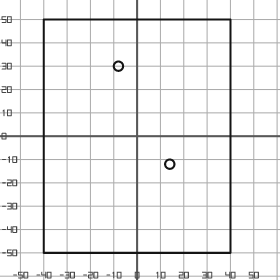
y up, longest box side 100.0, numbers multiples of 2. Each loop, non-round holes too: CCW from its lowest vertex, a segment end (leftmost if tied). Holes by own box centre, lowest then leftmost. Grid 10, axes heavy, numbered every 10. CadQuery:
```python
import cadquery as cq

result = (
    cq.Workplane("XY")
    .moveTo(-40.0, -50.0)
    .lineTo(40.0, -50.0)
    .lineTo(40.0, 50.0)
    .lineTo(-40.0, 50.0)
    .close()
    .moveTo(14.0, -12.0)
    .circle(2.0)
    .moveTo(-8.0, 30.0)
    .circle(2.0)
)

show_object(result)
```